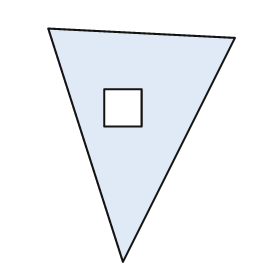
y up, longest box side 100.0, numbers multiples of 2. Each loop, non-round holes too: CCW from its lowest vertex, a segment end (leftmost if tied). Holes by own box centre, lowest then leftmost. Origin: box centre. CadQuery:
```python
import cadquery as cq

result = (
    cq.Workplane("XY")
    .moveTo(-8.0, -50.0)
    .lineTo(40.0, 46.0)
    .lineTo(-40.0, 50.0)
    .close()
    .moveTo(-16.0, 8.0)
    .lineTo(0.0, 8.0)
    .lineTo(0.0, 24.0)
    .lineTo(-16.0, 24.0)
    .close()
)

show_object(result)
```